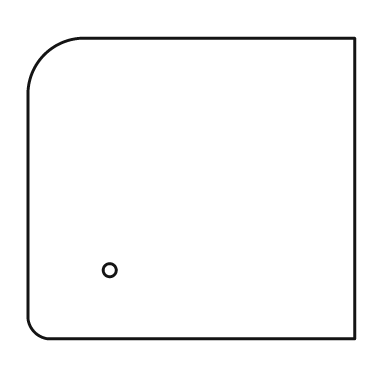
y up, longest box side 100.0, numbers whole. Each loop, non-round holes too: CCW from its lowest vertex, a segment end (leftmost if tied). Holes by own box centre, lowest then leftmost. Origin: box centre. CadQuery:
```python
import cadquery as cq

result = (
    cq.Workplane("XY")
    .moveTo(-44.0, -46.0)
    .lineTo(50.0, -46.0)
    .lineTo(50.0, 46.0)
    .lineTo(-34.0, 46.0)
    .threePointArc((-45.0, 41.0), (-50.0, 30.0))
    .lineTo(-50.0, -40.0)
    .threePointArc((-48.0, -44.0), (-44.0, -46.0))
    .close()
    .moveTo(-25.0, -25.0)
    .circle(2.0)
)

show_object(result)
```